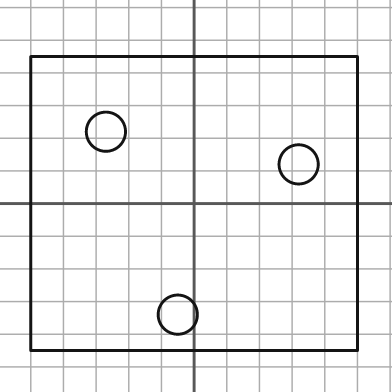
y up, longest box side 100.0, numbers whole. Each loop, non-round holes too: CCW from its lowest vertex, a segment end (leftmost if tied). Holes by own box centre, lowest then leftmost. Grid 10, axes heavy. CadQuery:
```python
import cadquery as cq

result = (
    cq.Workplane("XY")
    .moveTo(-50.0, -45.0)
    .lineTo(50.0, -45.0)
    .lineTo(50.0, 45.0)
    .lineTo(-50.0, 45.0)
    .close()
    .moveTo(-5.0, -34.0)
    .circle(6.0)
    .moveTo(32.0, 12.0)
    .circle(6.0)
    .moveTo(-27.0, 22.0)
    .circle(6.0)
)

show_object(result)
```